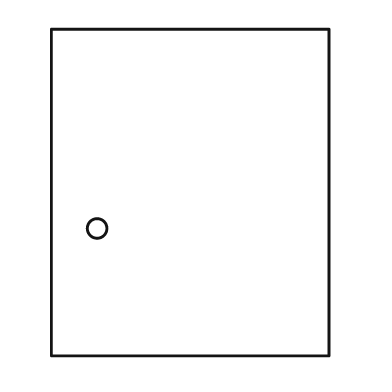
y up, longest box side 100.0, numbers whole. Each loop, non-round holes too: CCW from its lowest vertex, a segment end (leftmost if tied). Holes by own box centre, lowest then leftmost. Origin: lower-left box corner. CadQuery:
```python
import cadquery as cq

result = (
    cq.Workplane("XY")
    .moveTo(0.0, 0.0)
    .lineTo(85.0, 0.0)
    .lineTo(85.0, 100.0)
    .lineTo(0.0, 100.0)
    .close()
    .moveTo(14.0, 39.0)
    .circle(3.0)
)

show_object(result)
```